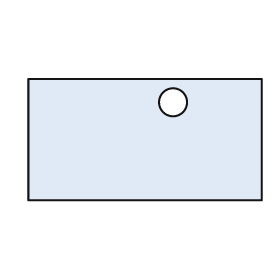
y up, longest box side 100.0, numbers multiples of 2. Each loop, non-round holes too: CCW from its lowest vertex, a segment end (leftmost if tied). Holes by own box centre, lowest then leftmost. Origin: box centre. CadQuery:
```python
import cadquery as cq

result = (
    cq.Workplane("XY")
    .moveTo(-50.0, -26.0)
    .lineTo(50.0, -26.0)
    .lineTo(50.0, 26.0)
    .lineTo(-50.0, 26.0)
    .close()
    .moveTo(12.0, 16.0)
    .circle(6.0)
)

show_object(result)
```